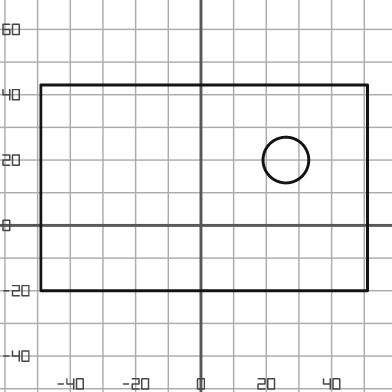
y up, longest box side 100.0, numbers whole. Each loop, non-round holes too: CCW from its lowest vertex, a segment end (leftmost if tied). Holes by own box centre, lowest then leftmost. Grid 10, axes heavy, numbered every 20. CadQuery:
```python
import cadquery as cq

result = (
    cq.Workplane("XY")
    .moveTo(-49.0, -20.0)
    .lineTo(51.0, -20.0)
    .lineTo(51.0, 43.0)
    .lineTo(-49.0, 43.0)
    .close()
    .moveTo(26.0, 20.0)
    .circle(7.0)
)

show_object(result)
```